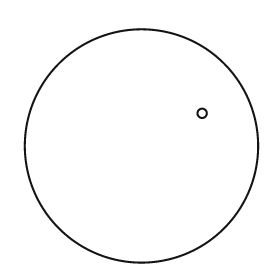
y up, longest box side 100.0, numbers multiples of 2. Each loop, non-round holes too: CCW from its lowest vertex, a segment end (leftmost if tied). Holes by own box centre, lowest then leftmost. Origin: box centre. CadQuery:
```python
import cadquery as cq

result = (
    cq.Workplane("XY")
    .moveTo(0.0, 0.0)
    .circle(50.0)
    .moveTo(26.0, 14.0)
    .circle(2.0)
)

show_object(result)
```